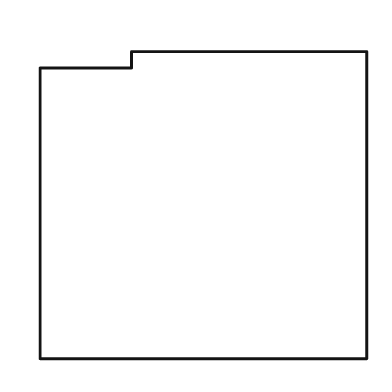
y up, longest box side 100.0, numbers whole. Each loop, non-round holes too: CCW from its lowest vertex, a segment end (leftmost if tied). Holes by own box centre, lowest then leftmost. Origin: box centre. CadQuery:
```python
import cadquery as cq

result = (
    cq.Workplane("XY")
    .moveTo(-50.0, -47.0)
    .lineTo(50.0, -47.0)
    .lineTo(50.0, 47.0)
    .lineTo(-22.0, 47.0)
    .lineTo(-22.0, 42.0)
    .lineTo(-50.0, 42.0)
    .close()
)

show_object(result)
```